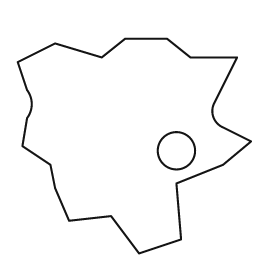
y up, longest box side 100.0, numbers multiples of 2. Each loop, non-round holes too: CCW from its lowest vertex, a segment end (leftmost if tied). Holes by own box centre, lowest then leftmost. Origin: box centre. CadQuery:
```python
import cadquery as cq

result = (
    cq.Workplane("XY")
    .moveTo(2.0, -46.0)
    .lineTo(20.0, -40.0)
    .lineTo(18.0, -16.0)
    .lineTo(38.0, -8.0)
    .lineTo(50.0, 2.0)
    .lineTo(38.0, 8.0)
    .threePointArc((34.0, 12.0), (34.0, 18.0))
    .lineTo(44.0, 38.0)
    .lineTo(24.0, 38.0)
    .lineTo(14.0, 46.0)
    .lineTo(-4.0, 46.0)
    .lineTo(-14.0, 38.0)
    .lineTo(-34.0, 44.0)
    .lineTo(-50.0, 36.0)
    .lineTo(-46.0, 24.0)
    .threePointArc((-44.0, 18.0), (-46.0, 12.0))
    .lineTo(-48.0, 0.0)
    .lineTo(-36.0, -8.0)
    .lineTo(-34.0, -18.0)
    .lineTo(-28.0, -32.0)
    .lineTo(-10.0, -30.0)
    .close()
    .moveTo(18.0, -2.0)
    .circle(8.0)
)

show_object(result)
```